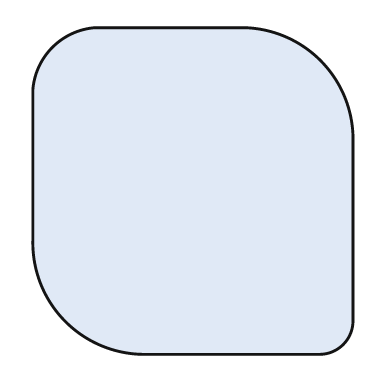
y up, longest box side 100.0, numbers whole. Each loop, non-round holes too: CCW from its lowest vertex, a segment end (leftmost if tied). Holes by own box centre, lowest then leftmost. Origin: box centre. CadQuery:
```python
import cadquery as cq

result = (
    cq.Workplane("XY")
    .moveTo(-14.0, -50.0)
    .lineTo(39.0, -50.0)
    .threePointArc((46.0, -47.0), (49.0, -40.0))
    .lineTo(49.0, 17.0)
    .threePointArc((39.0, 40.0), (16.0, 50.0))
    .lineTo(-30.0, 50.0)
    .threePointArc((-43.0, 44.0), (-49.0, 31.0))
    .lineTo(-49.0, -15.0)
    .threePointArc((-39.0, -40.0), (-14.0, -50.0))
    .close()
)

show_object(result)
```